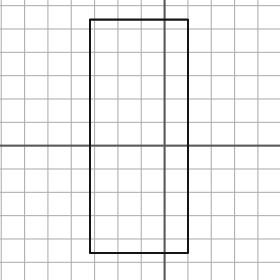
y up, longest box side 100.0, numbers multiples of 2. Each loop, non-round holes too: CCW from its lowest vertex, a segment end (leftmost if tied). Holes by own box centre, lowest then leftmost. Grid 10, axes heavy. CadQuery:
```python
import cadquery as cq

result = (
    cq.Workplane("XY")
    .moveTo(-32.0, -46.0)
    .lineTo(10.0, -46.0)
    .lineTo(10.0, 54.0)
    .lineTo(-32.0, 54.0)
    .close()
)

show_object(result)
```